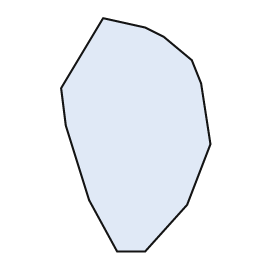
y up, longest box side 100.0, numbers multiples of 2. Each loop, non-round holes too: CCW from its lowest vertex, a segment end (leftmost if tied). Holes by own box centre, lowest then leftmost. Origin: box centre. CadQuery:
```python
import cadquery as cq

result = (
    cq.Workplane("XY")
    .moveTo(-8.0, -50.0)
    .lineTo(4.0, -50.0)
    .lineTo(22.0, -30.0)
    .lineTo(32.0, -4.0)
    .lineTo(28.0, 22.0)
    .lineTo(24.0, 32.0)
    .lineTo(12.0, 42.0)
    .lineTo(4.0, 46.0)
    .lineTo(-14.0, 50.0)
    .lineTo(-32.0, 20.0)
    .lineTo(-30.0, 4.0)
    .lineTo(-20.0, -28.0)
    .close()
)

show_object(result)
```